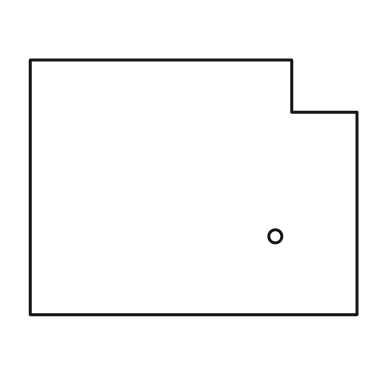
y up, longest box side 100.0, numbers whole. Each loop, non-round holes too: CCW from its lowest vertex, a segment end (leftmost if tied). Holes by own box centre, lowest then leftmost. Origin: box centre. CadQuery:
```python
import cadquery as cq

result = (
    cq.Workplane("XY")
    .moveTo(-50.0, -39.0)
    .lineTo(50.0, -39.0)
    .lineTo(50.0, 23.0)
    .lineTo(30.0, 23.0)
    .lineTo(30.0, 39.0)
    .lineTo(-50.0, 39.0)
    .close()
    .moveTo(25.0, -15.0)
    .circle(2.0)
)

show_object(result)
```